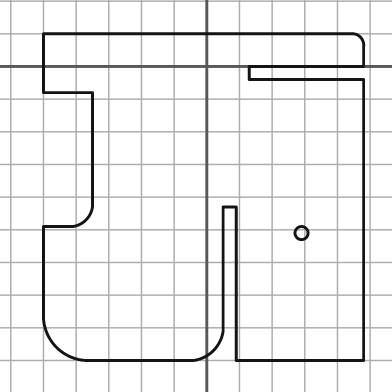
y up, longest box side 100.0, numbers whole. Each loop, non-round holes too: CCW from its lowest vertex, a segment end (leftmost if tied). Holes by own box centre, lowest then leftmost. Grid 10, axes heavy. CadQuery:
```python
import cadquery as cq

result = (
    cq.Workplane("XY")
    .moveTo(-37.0, -90.0)
    .lineTo(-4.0, -90.0)
    .threePointArc((2.0, -87.0), (5.0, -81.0))
    .lineTo(5.0, -43.0)
    .lineTo(9.0, -43.0)
    .lineTo(9.0, -90.0)
    .lineTo(48.0, -90.0)
    .lineTo(48.0, -4.0)
    .lineTo(13.0, -4.0)
    .lineTo(13.0, 0.0)
    .lineTo(48.0, 0.0)
    .lineTo(48.0, 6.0)
    .threePointArc((47.0, 9.0), (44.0, 10.0))
    .lineTo(-50.0, 10.0)
    .lineTo(-50.0, -8.0)
    .lineTo(-35.0, -8.0)
    .lineTo(-35.0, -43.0)
    .threePointArc((-37.0, -47.0), (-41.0, -49.0))
    .lineTo(-50.0, -49.0)
    .lineTo(-50.0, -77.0)
    .threePointArc((-46.0, -86.0), (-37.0, -90.0))
    .close()
    .moveTo(29.0, -51.0)
    .circle(2.0)
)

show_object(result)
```